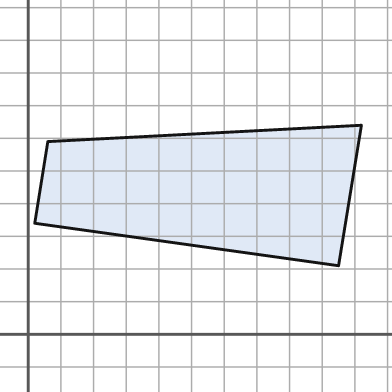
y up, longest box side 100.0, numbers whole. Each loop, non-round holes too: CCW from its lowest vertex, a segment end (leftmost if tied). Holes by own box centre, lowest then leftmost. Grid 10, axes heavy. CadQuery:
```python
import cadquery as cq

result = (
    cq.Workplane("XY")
    .moveTo(95.0, 21.0)
    .lineTo(102.0, 64.0)
    .lineTo(6.0, 59.0)
    .lineTo(2.0, 34.0)
    .close()
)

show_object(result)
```